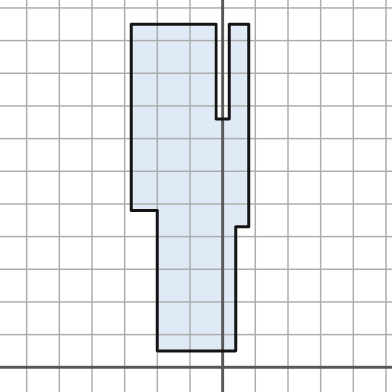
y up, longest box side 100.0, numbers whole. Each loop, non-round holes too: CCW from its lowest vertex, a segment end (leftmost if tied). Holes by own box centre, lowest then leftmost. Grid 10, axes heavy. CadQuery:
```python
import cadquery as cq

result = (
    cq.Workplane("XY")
    .moveTo(-20.0, 5.0)
    .lineTo(4.0, 5.0)
    .lineTo(4.0, 43.0)
    .lineTo(8.0, 43.0)
    .lineTo(8.0, 105.0)
    .lineTo(2.0, 105.0)
    .lineTo(2.0, 76.0)
    .lineTo(-2.0, 76.0)
    .lineTo(-2.0, 105.0)
    .lineTo(-28.0, 105.0)
    .lineTo(-28.0, 48.0)
    .lineTo(-20.0, 48.0)
    .close()
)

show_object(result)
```